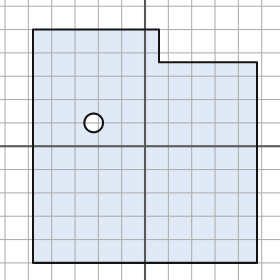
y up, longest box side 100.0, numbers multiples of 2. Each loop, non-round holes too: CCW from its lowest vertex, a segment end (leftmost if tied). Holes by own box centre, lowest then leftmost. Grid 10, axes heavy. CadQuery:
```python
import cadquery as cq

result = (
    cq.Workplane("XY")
    .moveTo(-48.0, -50.0)
    .lineTo(48.0, -50.0)
    .lineTo(48.0, 36.0)
    .lineTo(6.0, 36.0)
    .lineTo(6.0, 50.0)
    .lineTo(-48.0, 50.0)
    .close()
    .moveTo(-22.0, 10.0)
    .circle(4.0)
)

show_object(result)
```